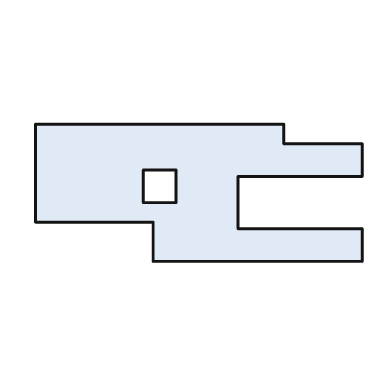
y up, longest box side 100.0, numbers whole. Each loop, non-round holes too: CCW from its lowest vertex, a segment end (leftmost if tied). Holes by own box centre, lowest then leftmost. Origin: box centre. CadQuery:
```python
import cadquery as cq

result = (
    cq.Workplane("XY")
    .moveTo(-14.0, -21.0)
    .lineTo(50.0, -21.0)
    .lineTo(50.0, -11.0)
    .lineTo(12.0, -11.0)
    .lineTo(12.0, 5.0)
    .lineTo(50.0, 5.0)
    .lineTo(50.0, 15.0)
    .lineTo(26.0, 15.0)
    .lineTo(26.0, 21.0)
    .lineTo(-50.0, 21.0)
    .lineTo(-50.0, -9.0)
    .lineTo(-14.0, -9.0)
    .close()
    .moveTo(-17.0, -3.0)
    .lineTo(-7.0, -3.0)
    .lineTo(-7.0, 7.0)
    .lineTo(-17.0, 7.0)
    .close()
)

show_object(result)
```